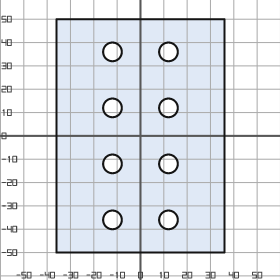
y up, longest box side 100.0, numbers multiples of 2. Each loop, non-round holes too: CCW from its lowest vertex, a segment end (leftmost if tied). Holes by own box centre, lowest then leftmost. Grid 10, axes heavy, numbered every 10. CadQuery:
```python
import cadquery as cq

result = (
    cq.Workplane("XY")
    .moveTo(-36.0, -50.0)
    .lineTo(36.0, -50.0)
    .lineTo(36.0, 50.0)
    .lineTo(-36.0, 50.0)
    .close()
    .moveTo(-12.0, -36.0)
    .circle(4.0)
    .moveTo(12.0, -36.0)
    .circle(4.0)
    .moveTo(-12.0, -12.0)
    .circle(4.0)
    .moveTo(12.0, -12.0)
    .circle(4.0)
    .moveTo(-12.0, 12.0)
    .circle(4.0)
    .moveTo(12.0, 12.0)
    .circle(4.0)
    .moveTo(-12.0, 36.0)
    .circle(4.0)
    .moveTo(12.0, 36.0)
    .circle(4.0)
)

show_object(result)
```